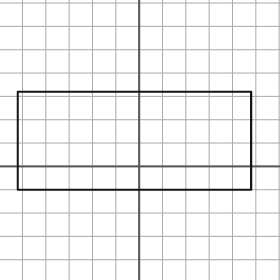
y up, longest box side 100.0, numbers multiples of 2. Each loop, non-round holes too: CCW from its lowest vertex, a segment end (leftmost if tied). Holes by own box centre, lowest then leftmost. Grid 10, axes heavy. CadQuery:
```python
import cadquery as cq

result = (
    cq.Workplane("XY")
    .moveTo(-52.0, -10.0)
    .lineTo(48.0, -10.0)
    .lineTo(48.0, 32.0)
    .lineTo(-52.0, 32.0)
    .close()
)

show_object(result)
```